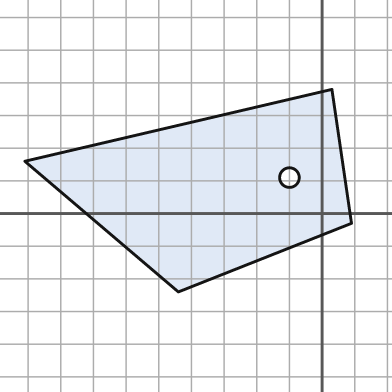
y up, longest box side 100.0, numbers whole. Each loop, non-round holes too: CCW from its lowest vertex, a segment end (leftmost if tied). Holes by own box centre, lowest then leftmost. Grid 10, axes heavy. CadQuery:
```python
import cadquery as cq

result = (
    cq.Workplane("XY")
    .moveTo(-44.0, -24.0)
    .lineTo(9.0, -3.0)
    .lineTo(3.0, 38.0)
    .lineTo(-91.0, 16.0)
    .close()
    .moveTo(-10.0, 11.0)
    .circle(3.0)
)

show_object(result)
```